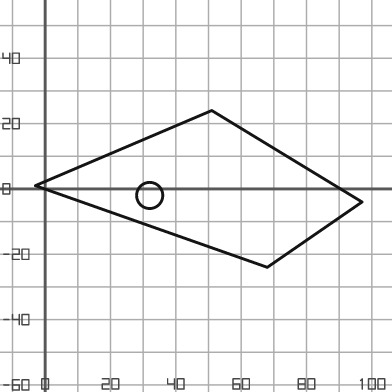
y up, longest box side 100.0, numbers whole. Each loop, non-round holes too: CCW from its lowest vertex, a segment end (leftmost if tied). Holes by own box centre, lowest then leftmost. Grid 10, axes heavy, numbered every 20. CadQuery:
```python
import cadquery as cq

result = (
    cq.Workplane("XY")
    .moveTo(68.0, -24.0)
    .lineTo(97.0, -4.0)
    .lineTo(51.0, 24.0)
    .lineTo(-3.0, 1.0)
    .close()
    .moveTo(32.0, -2.0)
    .circle(4.0)
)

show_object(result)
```